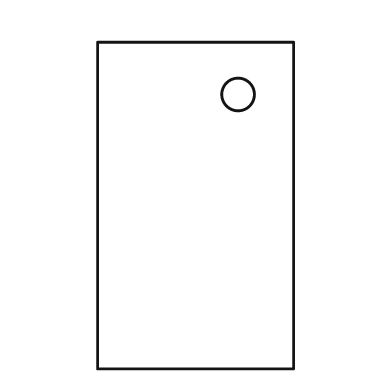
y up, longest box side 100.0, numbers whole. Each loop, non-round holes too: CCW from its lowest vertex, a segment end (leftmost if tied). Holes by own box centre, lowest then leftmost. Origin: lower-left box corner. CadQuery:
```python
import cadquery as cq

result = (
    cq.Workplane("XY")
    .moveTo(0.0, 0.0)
    .lineTo(60.0, 0.0)
    .lineTo(60.0, 100.0)
    .lineTo(0.0, 100.0)
    .close()
    .moveTo(43.0, 84.0)
    .circle(5.0)
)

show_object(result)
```